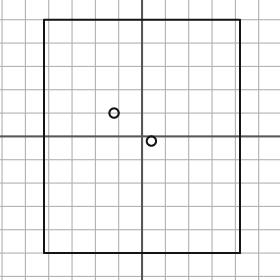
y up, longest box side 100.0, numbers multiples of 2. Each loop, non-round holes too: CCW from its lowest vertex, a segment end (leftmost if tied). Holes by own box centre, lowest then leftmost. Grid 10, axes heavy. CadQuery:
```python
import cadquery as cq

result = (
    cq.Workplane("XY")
    .moveTo(-42.0, -50.0)
    .lineTo(42.0, -50.0)
    .lineTo(42.0, 50.0)
    .lineTo(-42.0, 50.0)
    .close()
    .moveTo(4.0, -2.0)
    .circle(2.0)
    .moveTo(-12.0, 10.0)
    .circle(2.0)
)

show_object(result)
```